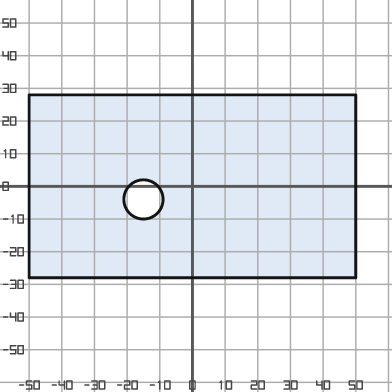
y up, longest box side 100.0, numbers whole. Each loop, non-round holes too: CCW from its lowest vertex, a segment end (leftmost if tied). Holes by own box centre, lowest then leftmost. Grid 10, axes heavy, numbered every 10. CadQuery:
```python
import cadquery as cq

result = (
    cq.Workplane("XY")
    .moveTo(-50.0, -28.0)
    .lineTo(50.0, -28.0)
    .lineTo(50.0, 28.0)
    .lineTo(-50.0, 28.0)
    .close()
    .moveTo(-15.0, -4.0)
    .circle(6.0)
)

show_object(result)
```